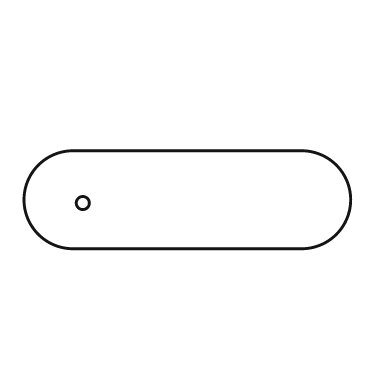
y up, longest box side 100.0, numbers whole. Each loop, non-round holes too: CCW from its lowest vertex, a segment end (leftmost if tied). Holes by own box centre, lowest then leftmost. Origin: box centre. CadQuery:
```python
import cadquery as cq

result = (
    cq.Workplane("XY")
    .moveTo(-35.0, -15.0)
    .lineTo(35.0, -15.0)
    .threePointArc((50.0, 0.0), (35.0, 15.0))
    .lineTo(-35.0, 15.0)
    .threePointArc((-50.0, 0.0), (-35.0, -15.0))
    .close()
    .moveTo(-32.0, -1.0)
    .circle(2.0)
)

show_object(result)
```